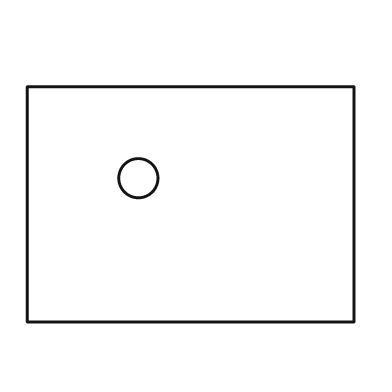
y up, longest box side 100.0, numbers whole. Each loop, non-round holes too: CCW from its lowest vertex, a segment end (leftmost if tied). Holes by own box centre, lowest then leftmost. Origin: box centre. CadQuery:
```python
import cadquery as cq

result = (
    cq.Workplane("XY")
    .moveTo(-50.0, -36.0)
    .lineTo(50.0, -36.0)
    .lineTo(50.0, 36.0)
    .lineTo(-50.0, 36.0)
    .close()
    .moveTo(-16.0, 8.0)
    .circle(6.0)
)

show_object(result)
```